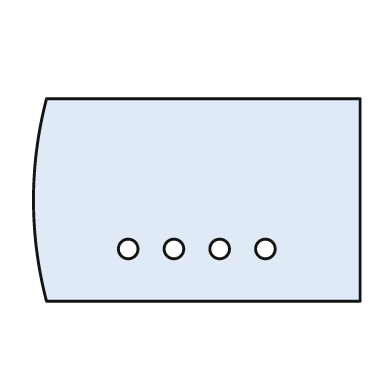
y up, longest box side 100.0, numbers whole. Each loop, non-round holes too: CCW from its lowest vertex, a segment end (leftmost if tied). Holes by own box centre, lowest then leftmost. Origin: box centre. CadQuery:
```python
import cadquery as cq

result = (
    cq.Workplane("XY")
    .moveTo(-46.0, -31.0)
    .lineTo(50.0, -31.0)
    .lineTo(50.0, 31.0)
    .lineTo(-46.0, 31.0)
    .threePointArc((-50.0, 0.0), (-46.0, -31.0))
    .close()
    .moveTo(-21.0, -15.0)
    .circle(3.0)
    .moveTo(-7.0, -15.0)
    .circle(3.0)
    .moveTo(7.0, -15.0)
    .circle(3.0)
    .moveTo(21.0, -15.0)
    .circle(3.0)
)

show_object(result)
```